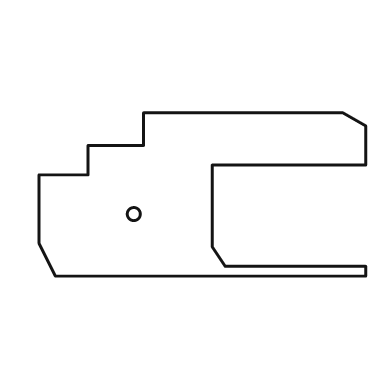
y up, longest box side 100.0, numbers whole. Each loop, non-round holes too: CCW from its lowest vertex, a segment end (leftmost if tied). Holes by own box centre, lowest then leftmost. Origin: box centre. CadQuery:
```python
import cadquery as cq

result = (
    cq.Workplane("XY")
    .moveTo(-45.0, -25.0)
    .lineTo(50.0, -25.0)
    .lineTo(50.0, -22.0)
    .lineTo(7.0, -22.0)
    .lineTo(3.0, -16.0)
    .lineTo(3.0, 9.0)
    .lineTo(50.0, 9.0)
    .lineTo(50.0, 21.0)
    .lineTo(43.0, 25.0)
    .lineTo(-18.0, 25.0)
    .lineTo(-18.0, 15.0)
    .lineTo(-35.0, 15.0)
    .lineTo(-35.0, 6.0)
    .lineTo(-50.0, 6.0)
    .lineTo(-50.0, -15.0)
    .close()
    .moveTo(-21.0, -6.0)
    .circle(2.0)
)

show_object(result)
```